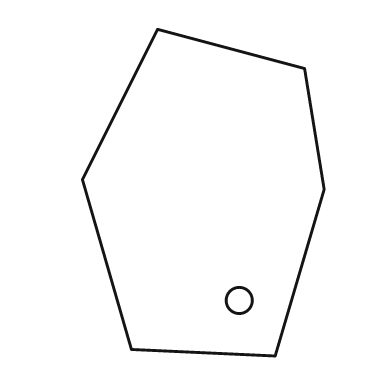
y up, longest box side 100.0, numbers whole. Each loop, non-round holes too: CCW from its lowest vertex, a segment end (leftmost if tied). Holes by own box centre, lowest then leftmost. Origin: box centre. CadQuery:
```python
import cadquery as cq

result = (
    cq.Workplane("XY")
    .moveTo(22.0, -50.0)
    .lineTo(37.0, 1.0)
    .lineTo(31.0, 38.0)
    .lineTo(-14.0, 50.0)
    .lineTo(-37.0, 4.0)
    .lineTo(-22.0, -48.0)
    .close()
    .moveTo(11.0, -33.0)
    .circle(4.0)
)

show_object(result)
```